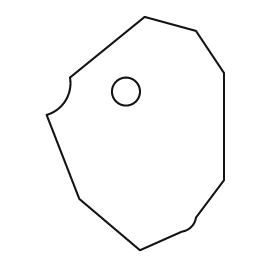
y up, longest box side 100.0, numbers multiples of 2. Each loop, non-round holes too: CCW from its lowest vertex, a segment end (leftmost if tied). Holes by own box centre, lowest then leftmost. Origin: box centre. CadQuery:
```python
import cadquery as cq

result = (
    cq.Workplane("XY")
    .moveTo(2.0, -50.0)
    .lineTo(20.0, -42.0)
    .threePointArc((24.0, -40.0), (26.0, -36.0))
    .lineTo(38.0, -20.0)
    .lineTo(38.0, 26.0)
    .lineTo(26.0, 44.0)
    .lineTo(4.0, 50.0)
    .lineTo(-28.0, 24.0)
    .threePointArc((-30.0, 14.0), (-38.0, 8.0))
    .lineTo(-24.0, -28.0)
    .close()
    .moveTo(-4.0, 18.0)
    .circle(6.0)
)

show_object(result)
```